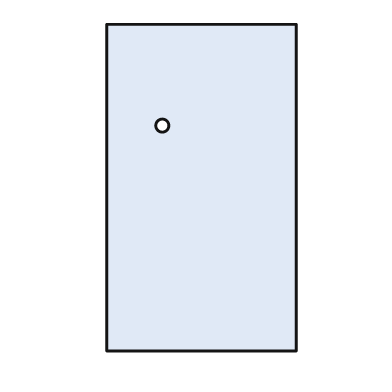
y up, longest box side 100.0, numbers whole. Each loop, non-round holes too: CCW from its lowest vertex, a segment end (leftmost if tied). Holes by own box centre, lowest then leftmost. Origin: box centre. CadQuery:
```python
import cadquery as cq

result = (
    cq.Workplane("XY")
    .moveTo(-29.0, -50.0)
    .lineTo(29.0, -50.0)
    .lineTo(29.0, 50.0)
    .lineTo(-29.0, 50.0)
    .close()
    .moveTo(-12.0, 19.0)
    .circle(2.0)
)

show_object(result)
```